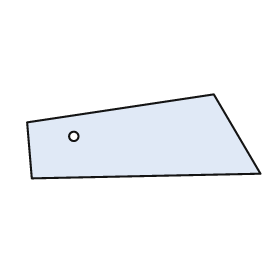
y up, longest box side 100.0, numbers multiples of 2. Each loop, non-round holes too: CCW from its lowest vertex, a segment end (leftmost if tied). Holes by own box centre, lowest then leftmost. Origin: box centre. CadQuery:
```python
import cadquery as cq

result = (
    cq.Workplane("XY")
    .moveTo(-48.0, -18.0)
    .lineTo(50.0, -16.0)
    .lineTo(30.0, 18.0)
    .lineTo(-50.0, 6.0)
    .close()
    .moveTo(-30.0, 0.0)
    .circle(2.0)
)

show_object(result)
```